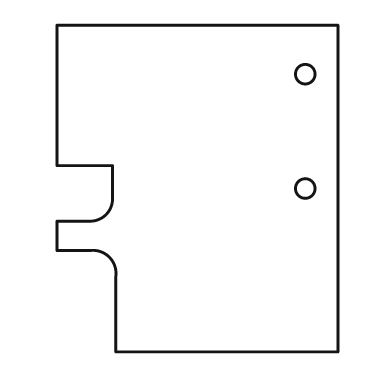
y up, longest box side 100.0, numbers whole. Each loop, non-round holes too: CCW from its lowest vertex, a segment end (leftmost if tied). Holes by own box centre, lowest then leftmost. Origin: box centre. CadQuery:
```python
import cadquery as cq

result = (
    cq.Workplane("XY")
    .moveTo(-25.0, -50.0)
    .lineTo(43.0, -50.0)
    .lineTo(43.0, 50.0)
    .lineTo(-43.0, 50.0)
    .lineTo(-43.0, 7.0)
    .lineTo(-26.0, 7.0)
    .lineTo(-26.0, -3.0)
    .threePointArc((-28.0, -8.0), (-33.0, -10.0))
    .lineTo(-43.0, -10.0)
    .lineTo(-43.0, -19.0)
    .lineTo(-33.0, -19.0)
    .threePointArc((-27.0, -21.0), (-25.0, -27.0))
    .close()
    .moveTo(33.0, 0.0)
    .circle(3.0)
    .moveTo(33.0, 35.0)
    .circle(3.0)
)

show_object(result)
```